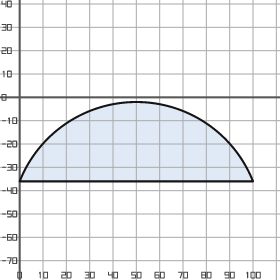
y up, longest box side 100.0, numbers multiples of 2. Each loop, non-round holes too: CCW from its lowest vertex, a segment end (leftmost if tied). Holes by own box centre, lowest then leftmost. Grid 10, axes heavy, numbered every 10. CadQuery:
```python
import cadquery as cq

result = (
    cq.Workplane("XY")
    .moveTo(0.0, -36.0)
    .lineTo(100.0, -36.0)
    .threePointArc((50.0, -2.0), (0.0, -36.0))
    .close()
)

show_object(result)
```